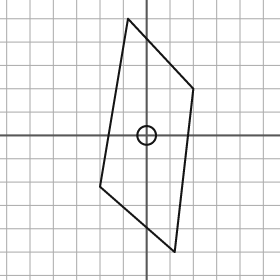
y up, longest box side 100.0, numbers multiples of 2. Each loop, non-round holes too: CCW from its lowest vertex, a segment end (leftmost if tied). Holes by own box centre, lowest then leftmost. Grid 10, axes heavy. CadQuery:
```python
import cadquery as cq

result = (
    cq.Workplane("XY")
    .moveTo(12.0, -50.0)
    .lineTo(20.0, 20.0)
    .lineTo(-8.0, 50.0)
    .lineTo(-20.0, -22.0)
    .close()
    .moveTo(0.0, 0.0)
    .circle(4.0)
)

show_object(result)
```